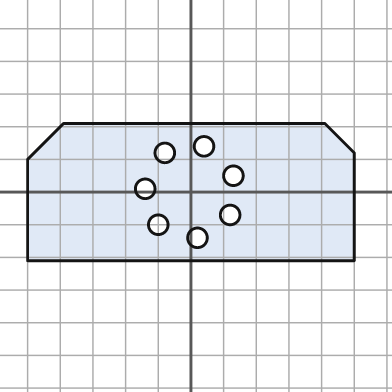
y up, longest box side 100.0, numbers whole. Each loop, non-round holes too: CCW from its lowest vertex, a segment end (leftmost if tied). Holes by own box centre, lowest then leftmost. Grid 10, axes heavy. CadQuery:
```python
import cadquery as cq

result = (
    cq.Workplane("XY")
    .moveTo(-50.0, -21.0)
    .lineTo(50.0, -21.0)
    .lineTo(50.0, 12.0)
    .lineTo(41.0, 21.0)
    .lineTo(-39.0, 21.0)
    .lineTo(-50.0, 10.0)
    .close()
    .moveTo(2.0, -14.0)
    .circle(3.0)
    .moveTo(-10.0, -10.0)
    .circle(3.0)
    .moveTo(12.0, -7.0)
    .circle(3.0)
    .moveTo(-14.0, 1.0)
    .circle(3.0)
    .moveTo(13.0, 5.0)
    .circle(3.0)
    .moveTo(-8.0, 12.0)
    .circle(3.0)
    .moveTo(4.0, 14.0)
    .circle(3.0)
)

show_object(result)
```